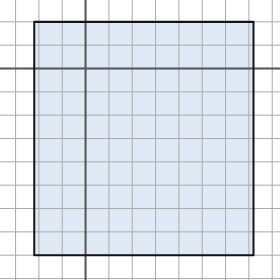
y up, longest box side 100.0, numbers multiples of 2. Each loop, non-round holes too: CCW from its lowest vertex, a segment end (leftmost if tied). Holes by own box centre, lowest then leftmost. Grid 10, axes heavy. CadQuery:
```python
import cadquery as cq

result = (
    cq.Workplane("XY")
    .moveTo(-22.0, -80.0)
    .lineTo(72.0, -80.0)
    .lineTo(72.0, 20.0)
    .lineTo(-22.0, 20.0)
    .close()
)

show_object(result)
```